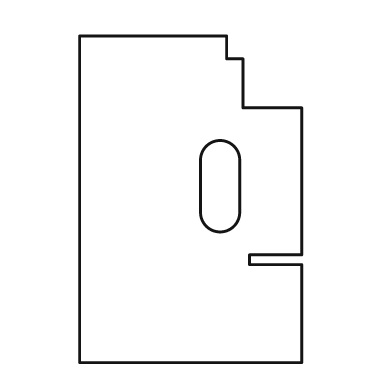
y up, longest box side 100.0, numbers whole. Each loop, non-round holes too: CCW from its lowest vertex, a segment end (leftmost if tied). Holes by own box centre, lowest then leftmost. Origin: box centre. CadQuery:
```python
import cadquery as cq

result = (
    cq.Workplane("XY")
    .moveTo(-34.0, -50.0)
    .lineTo(34.0, -50.0)
    .lineTo(34.0, -20.0)
    .lineTo(18.0, -20.0)
    .lineTo(18.0, -17.0)
    .lineTo(34.0, -17.0)
    .lineTo(34.0, 28.0)
    .lineTo(16.0, 28.0)
    .lineTo(16.0, 43.0)
    .lineTo(11.0, 43.0)
    .lineTo(11.0, 50.0)
    .lineTo(-34.0, 50.0)
    .close()
    .moveTo(3.0, -4.0)
    .threePointArc((9.0, -10.0), (15.0, -4.0))
    .lineTo(15.0, 12.0)
    .threePointArc((9.0, 18.0), (3.0, 12.0))
    .close()
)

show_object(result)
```